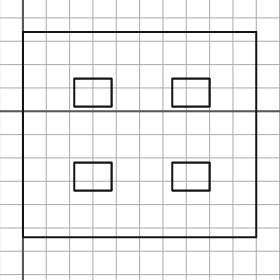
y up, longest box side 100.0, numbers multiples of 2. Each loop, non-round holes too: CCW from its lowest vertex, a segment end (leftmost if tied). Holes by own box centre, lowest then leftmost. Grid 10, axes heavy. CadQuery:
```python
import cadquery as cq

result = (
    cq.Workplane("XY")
    .moveTo(0.0, -54.0)
    .lineTo(100.0, -54.0)
    .lineTo(100.0, 34.0)
    .lineTo(0.0, 34.0)
    .close()
    .moveTo(22.0, -34.0)
    .lineTo(38.0, -34.0)
    .lineTo(38.0, -22.0)
    .lineTo(22.0, -22.0)
    .close()
    .moveTo(64.0, -34.0)
    .lineTo(80.0, -34.0)
    .lineTo(80.0, -22.0)
    .lineTo(64.0, -22.0)
    .close()
    .moveTo(22.0, 2.0)
    .lineTo(38.0, 2.0)
    .lineTo(38.0, 14.0)
    .lineTo(22.0, 14.0)
    .close()
    .moveTo(64.0, 2.0)
    .lineTo(80.0, 2.0)
    .lineTo(80.0, 14.0)
    .lineTo(64.0, 14.0)
    .close()
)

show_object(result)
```